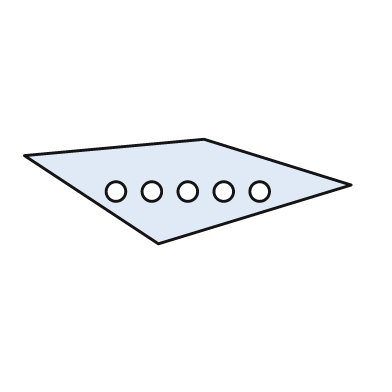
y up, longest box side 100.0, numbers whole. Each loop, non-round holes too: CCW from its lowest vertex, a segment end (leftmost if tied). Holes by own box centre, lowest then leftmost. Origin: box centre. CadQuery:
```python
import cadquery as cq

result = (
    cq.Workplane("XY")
    .moveTo(-9.0, -16.0)
    .lineTo(50.0, 2.0)
    .lineTo(5.0, 16.0)
    .lineTo(-50.0, 11.0)
    .close()
    .moveTo(-22.0, 0.0)
    .circle(3.0)
    .moveTo(-11.0, 0.0)
    .circle(3.0)
    .moveTo(0.0, 0.0)
    .circle(3.0)
    .moveTo(11.0, 0.0)
    .circle(3.0)
    .moveTo(22.0, 0.0)
    .circle(3.0)
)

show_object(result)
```